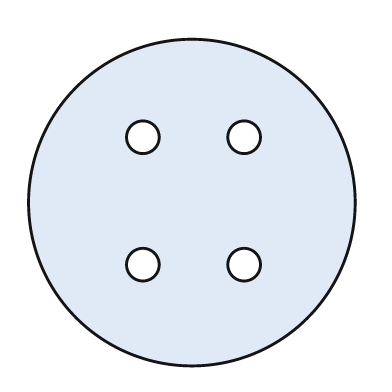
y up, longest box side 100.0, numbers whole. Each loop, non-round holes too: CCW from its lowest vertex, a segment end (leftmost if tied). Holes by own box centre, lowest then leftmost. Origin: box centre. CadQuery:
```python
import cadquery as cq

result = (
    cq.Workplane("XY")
    .moveTo(0.0, 0.0)
    .circle(50.0)
    .moveTo(-15.0, -19.0)
    .circle(5.0)
    .moveTo(16.0, -19.0)
    .circle(5.0)
    .moveTo(-15.0, 20.0)
    .circle(5.0)
    .moveTo(16.0, 20.0)
    .circle(5.0)
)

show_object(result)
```